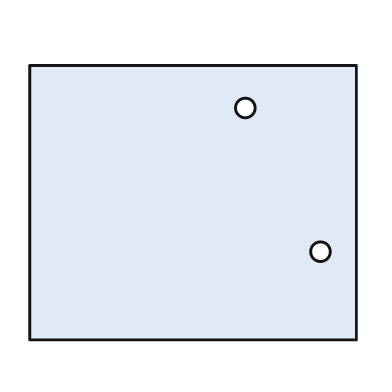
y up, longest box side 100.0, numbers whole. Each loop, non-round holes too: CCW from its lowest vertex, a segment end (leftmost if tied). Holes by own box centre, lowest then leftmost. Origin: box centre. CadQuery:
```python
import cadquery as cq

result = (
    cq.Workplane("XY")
    .moveTo(-50.0, -42.0)
    .lineTo(50.0, -42.0)
    .lineTo(50.0, 42.0)
    .lineTo(-50.0, 42.0)
    .close()
    .moveTo(39.0, -15.0)
    .circle(3.0)
    .moveTo(16.0, 29.0)
    .circle(3.0)
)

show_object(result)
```